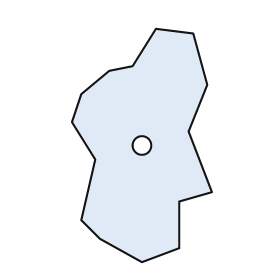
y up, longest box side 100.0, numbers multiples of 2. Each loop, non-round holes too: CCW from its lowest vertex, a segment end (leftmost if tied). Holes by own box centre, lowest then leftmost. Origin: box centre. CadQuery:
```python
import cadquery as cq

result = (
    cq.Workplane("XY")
    .moveTo(0.0, -50.0)
    .lineTo(16.0, -44.0)
    .lineTo(16.0, -24.0)
    .lineTo(30.0, -20.0)
    .lineTo(20.0, 6.0)
    .lineTo(28.0, 26.0)
    .lineTo(22.0, 48.0)
    .lineTo(6.0, 50.0)
    .lineTo(-4.0, 34.0)
    .lineTo(-14.0, 32.0)
    .lineTo(-26.0, 22.0)
    .lineTo(-30.0, 10.0)
    .lineTo(-20.0, -6.0)
    .lineTo(-26.0, -32.0)
    .lineTo(-18.0, -40.0)
    .close()
    .moveTo(0.0, 0.0)
    .circle(4.0)
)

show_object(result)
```